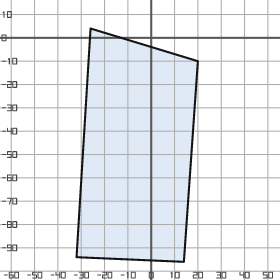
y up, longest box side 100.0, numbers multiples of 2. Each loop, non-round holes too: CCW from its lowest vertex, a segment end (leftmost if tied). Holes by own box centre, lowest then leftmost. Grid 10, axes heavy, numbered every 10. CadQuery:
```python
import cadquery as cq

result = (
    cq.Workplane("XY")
    .moveTo(14.0, -96.0)
    .lineTo(20.0, -10.0)
    .lineTo(-26.0, 4.0)
    .lineTo(-32.0, -94.0)
    .close()
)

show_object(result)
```